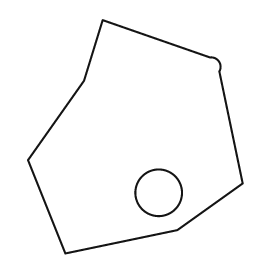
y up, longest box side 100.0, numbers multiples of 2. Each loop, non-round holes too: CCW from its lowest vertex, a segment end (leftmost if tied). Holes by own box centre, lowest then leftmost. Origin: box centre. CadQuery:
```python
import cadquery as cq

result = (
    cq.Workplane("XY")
    .moveTo(-30.0, -50.0)
    .lineTo(18.0, -40.0)
    .lineTo(46.0, -20.0)
    .lineTo(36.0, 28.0)
    .threePointArc((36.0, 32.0), (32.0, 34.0))
    .lineTo(-14.0, 50.0)
    .lineTo(-22.0, 24.0)
    .lineTo(-46.0, -10.0)
    .close()
    .moveTo(10.0, -24.0)
    .circle(10.0)
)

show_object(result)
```